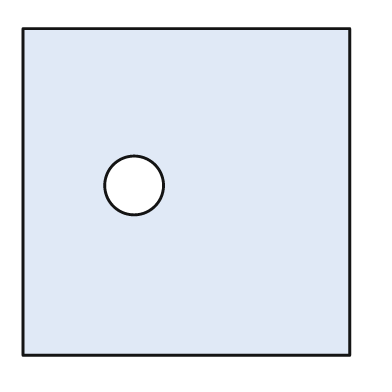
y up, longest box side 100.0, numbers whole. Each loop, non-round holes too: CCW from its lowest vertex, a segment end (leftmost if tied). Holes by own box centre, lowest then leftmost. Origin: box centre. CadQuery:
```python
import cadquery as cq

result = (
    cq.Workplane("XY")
    .moveTo(-50.0, -50.0)
    .lineTo(50.0, -50.0)
    .lineTo(50.0, 50.0)
    .lineTo(-50.0, 50.0)
    .close()
    .moveTo(-16.0, 2.0)
    .circle(9.0)
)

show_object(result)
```